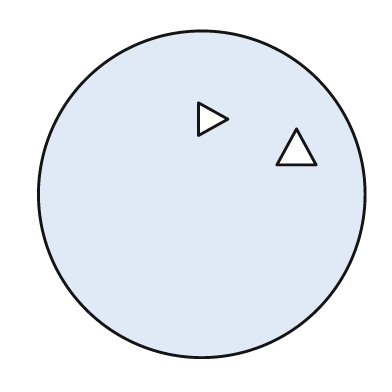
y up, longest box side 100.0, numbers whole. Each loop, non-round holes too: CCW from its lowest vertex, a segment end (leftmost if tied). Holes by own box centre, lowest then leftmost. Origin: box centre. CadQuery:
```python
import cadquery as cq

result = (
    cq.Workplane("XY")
    .moveTo(0.0, 0.0)
    .circle(50.0)
    .moveTo(23.0, 9.0)
    .lineTo(35.0, 9.0)
    .lineTo(29.0, 20.0)
    .close()
    .moveTo(-1.0, 18.0)
    .lineTo(8.0, 23.0)
    .lineTo(-1.0, 28.0)
    .close()
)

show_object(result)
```